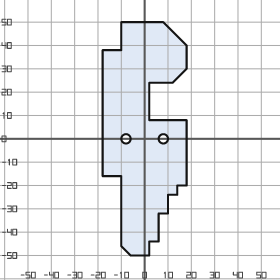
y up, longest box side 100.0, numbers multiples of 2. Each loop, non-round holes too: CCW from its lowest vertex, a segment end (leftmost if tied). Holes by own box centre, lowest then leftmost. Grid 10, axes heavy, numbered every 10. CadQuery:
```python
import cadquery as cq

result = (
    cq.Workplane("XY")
    .moveTo(-6.0, -50.0)
    .lineTo(2.0, -50.0)
    .lineTo(2.0, -44.0)
    .lineTo(6.0, -44.0)
    .lineTo(6.0, -32.0)
    .lineTo(10.0, -32.0)
    .lineTo(10.0, -24.0)
    .lineTo(14.0, -24.0)
    .lineTo(14.0, -20.0)
    .lineTo(18.0, -20.0)
    .lineTo(18.0, 8.0)
    .lineTo(2.0, 8.0)
    .lineTo(2.0, 24.0)
    .lineTo(12.0, 24.0)
    .lineTo(18.0, 30.0)
    .lineTo(18.0, 40.0)
    .lineTo(8.0, 50.0)
    .lineTo(-10.0, 50.0)
    .lineTo(-10.0, 38.0)
    .lineTo(-18.0, 38.0)
    .lineTo(-18.0, -16.0)
    .lineTo(-10.0, -16.0)
    .lineTo(-10.0, -46.0)
    .close()
    .moveTo(-8.0, 0.0)
    .circle(2.0)
    .moveTo(8.0, 0.0)
    .circle(2.0)
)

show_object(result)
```